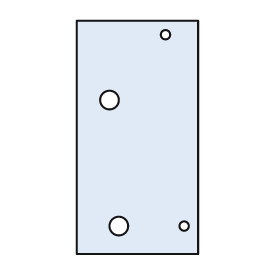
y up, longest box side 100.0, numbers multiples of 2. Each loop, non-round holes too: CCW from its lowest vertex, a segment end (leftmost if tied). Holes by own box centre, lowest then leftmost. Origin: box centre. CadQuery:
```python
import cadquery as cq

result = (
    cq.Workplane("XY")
    .moveTo(-26.0, -50.0)
    .lineTo(26.0, -50.0)
    .lineTo(26.0, 50.0)
    .lineTo(-26.0, 50.0)
    .close()
    .moveTo(-8.0, -38.0)
    .circle(4.0)
    .moveTo(20.0, -38.0)
    .circle(2.0)
    .moveTo(-12.0, 16.0)
    .circle(4.0)
    .moveTo(12.0, 44.0)
    .circle(2.0)
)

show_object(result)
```